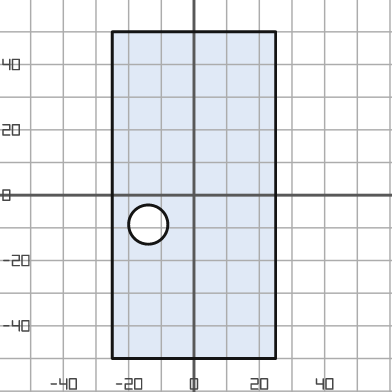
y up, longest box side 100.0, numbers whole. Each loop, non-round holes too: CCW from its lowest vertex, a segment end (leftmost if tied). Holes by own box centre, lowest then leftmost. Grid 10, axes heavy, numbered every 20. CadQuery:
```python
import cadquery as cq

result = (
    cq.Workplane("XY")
    .moveTo(-25.0, -50.0)
    .lineTo(25.0, -50.0)
    .lineTo(25.0, 50.0)
    .lineTo(-25.0, 50.0)
    .close()
    .moveTo(-14.0, -9.0)
    .circle(6.0)
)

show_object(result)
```